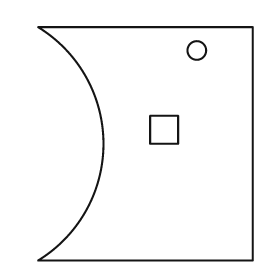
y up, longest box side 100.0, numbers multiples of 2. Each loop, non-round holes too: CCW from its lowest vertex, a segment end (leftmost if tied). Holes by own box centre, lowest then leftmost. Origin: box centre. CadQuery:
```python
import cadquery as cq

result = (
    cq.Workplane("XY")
    .moveTo(-46.0, -50.0)
    .lineTo(46.0, -50.0)
    .lineTo(46.0, 50.0)
    .lineTo(-46.0, 50.0)
    .threePointArc((-18.0, 0.0), (-46.0, -50.0))
    .close()
    .moveTo(2.0, 0.0)
    .lineTo(14.0, 0.0)
    .lineTo(14.0, 12.0)
    .lineTo(2.0, 12.0)
    .close()
    .moveTo(22.0, 40.0)
    .circle(4.0)
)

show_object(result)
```